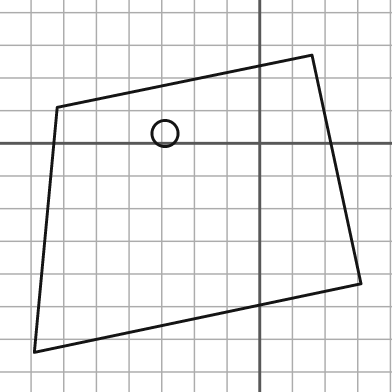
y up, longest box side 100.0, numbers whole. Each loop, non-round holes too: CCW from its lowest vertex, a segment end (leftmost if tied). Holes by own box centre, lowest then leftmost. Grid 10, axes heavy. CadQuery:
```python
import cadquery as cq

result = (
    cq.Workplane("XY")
    .moveTo(-69.0, -64.0)
    .lineTo(31.0, -43.0)
    .lineTo(16.0, 27.0)
    .lineTo(-62.0, 11.0)
    .close()
    .moveTo(-29.0, 3.0)
    .circle(4.0)
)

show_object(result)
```